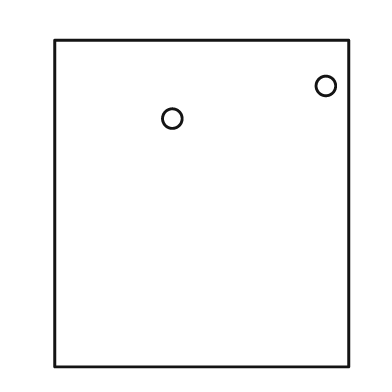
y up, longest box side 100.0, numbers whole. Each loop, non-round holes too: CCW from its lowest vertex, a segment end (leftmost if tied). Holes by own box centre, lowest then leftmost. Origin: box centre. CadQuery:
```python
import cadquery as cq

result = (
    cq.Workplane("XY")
    .moveTo(-45.0, -50.0)
    .lineTo(45.0, -50.0)
    .lineTo(45.0, 50.0)
    .lineTo(-45.0, 50.0)
    .close()
    .moveTo(-9.0, 26.0)
    .circle(3.0)
    .moveTo(38.0, 36.0)
    .circle(3.0)
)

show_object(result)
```